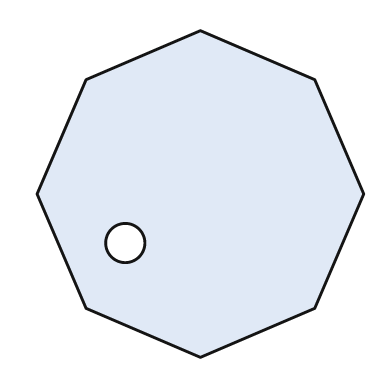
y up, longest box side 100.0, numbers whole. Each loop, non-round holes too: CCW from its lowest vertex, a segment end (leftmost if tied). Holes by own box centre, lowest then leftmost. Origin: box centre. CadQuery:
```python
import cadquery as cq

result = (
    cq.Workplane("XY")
    .moveTo(0.0, -50.0)
    .lineTo(35.0, -35.0)
    .lineTo(50.0, 0.0)
    .lineTo(35.0, 35.0)
    .lineTo(0.0, 50.0)
    .lineTo(-35.0, 35.0)
    .lineTo(-50.0, 0.0)
    .lineTo(-35.0, -35.0)
    .close()
    .moveTo(-23.0, -15.0)
    .circle(6.0)
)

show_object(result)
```